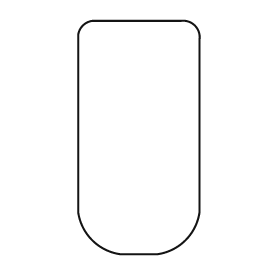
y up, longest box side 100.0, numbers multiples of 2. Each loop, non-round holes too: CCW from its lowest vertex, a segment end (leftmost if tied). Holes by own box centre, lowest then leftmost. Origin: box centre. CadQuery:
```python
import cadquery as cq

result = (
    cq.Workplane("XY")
    .moveTo(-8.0, -50.0)
    .lineTo(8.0, -50.0)
    .threePointArc((20.0, -44.0), (26.0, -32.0))
    .lineTo(26.0, 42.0)
    .threePointArc((24.0, 48.0), (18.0, 50.0))
    .lineTo(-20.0, 50.0)
    .threePointArc((-24.0, 48.0), (-26.0, 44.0))
    .lineTo(-26.0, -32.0)
    .threePointArc((-20.0, -44.0), (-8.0, -50.0))
    .close()
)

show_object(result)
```